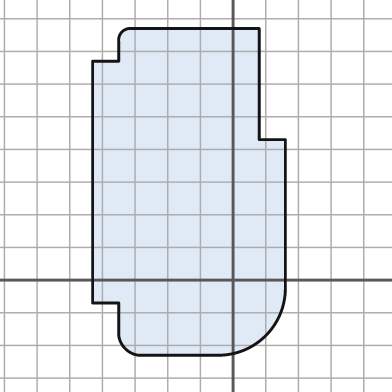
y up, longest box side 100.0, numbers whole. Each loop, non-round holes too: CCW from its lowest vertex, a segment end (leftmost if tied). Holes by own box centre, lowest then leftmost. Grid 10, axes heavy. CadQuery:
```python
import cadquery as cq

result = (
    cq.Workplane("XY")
    .moveTo(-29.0, -23.0)
    .lineTo(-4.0, -23.0)
    .threePointArc((10.0, -17.0), (16.0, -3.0))
    .lineTo(16.0, 43.0)
    .lineTo(8.0, 43.0)
    .lineTo(8.0, 77.0)
    .lineTo(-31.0, 77.0)
    .threePointArc((-34.0, 76.0), (-35.0, 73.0))
    .lineTo(-35.0, 67.0)
    .lineTo(-43.0, 67.0)
    .lineTo(-43.0, -7.0)
    .lineTo(-35.0, -7.0)
    .lineTo(-35.0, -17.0)
    .threePointArc((-33.0, -21.0), (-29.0, -23.0))
    .close()
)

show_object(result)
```